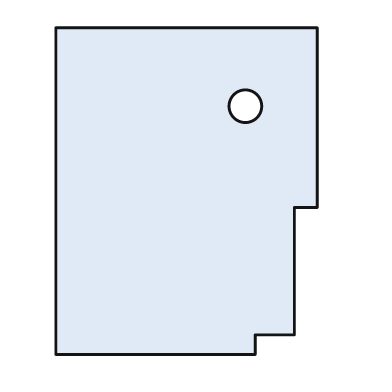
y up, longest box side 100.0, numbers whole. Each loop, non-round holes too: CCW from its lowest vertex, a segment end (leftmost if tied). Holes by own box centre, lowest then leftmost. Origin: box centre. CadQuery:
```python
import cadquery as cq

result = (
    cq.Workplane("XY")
    .moveTo(-40.0, -50.0)
    .lineTo(21.0, -50.0)
    .lineTo(21.0, -44.0)
    .lineTo(33.0, -44.0)
    .lineTo(33.0, -5.0)
    .lineTo(40.0, -5.0)
    .lineTo(40.0, 50.0)
    .lineTo(-40.0, 50.0)
    .close()
    .moveTo(18.0, 26.0)
    .circle(5.0)
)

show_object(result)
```